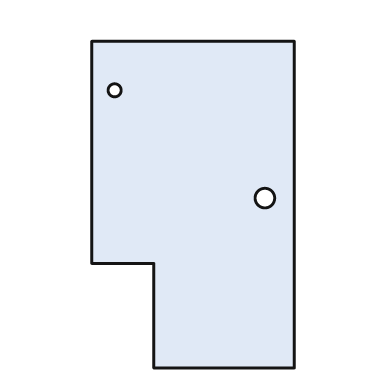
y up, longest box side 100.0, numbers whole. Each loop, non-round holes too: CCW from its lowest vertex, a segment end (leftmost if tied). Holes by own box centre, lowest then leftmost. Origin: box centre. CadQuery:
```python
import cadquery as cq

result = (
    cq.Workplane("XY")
    .moveTo(-12.0, -50.0)
    .lineTo(31.0, -50.0)
    .lineTo(31.0, 50.0)
    .lineTo(-31.0, 50.0)
    .lineTo(-31.0, -18.0)
    .lineTo(-12.0, -18.0)
    .close()
    .moveTo(22.0, 2.0)
    .circle(3.0)
    .moveTo(-24.0, 35.0)
    .circle(2.0)
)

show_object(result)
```